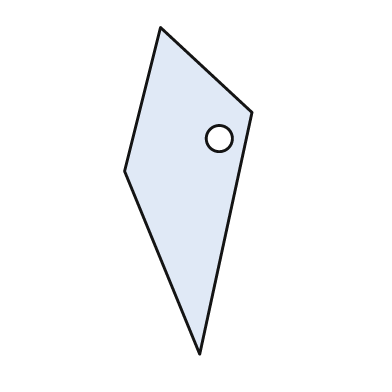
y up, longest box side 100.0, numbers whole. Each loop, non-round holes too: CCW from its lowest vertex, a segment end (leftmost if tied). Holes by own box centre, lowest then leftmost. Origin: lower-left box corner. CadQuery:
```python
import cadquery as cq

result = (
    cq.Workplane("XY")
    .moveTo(23.0, 0.0)
    .lineTo(39.0, 74.0)
    .lineTo(11.0, 100.0)
    .lineTo(0.0, 56.0)
    .close()
    .moveTo(29.0, 66.0)
    .circle(4.0)
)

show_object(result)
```